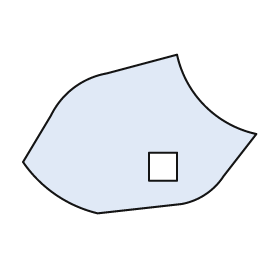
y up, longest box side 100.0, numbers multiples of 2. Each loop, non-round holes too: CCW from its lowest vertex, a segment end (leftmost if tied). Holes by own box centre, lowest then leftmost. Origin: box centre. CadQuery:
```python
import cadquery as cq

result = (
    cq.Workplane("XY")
    .moveTo(-18.0, -34.0)
    .lineTo(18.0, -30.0)
    .threePointArc((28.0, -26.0), (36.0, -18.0))
    .lineTo(50.0, 0.0)
    .threePointArc((28.0, 12.0), (16.0, 34.0))
    .lineTo(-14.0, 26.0)
    .threePointArc((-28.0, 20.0), (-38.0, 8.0))
    .lineTo(-50.0, -12.0)
    .threePointArc((-36.0, -26.0), (-18.0, -34.0))
    .close()
    .moveTo(4.0, -20.0)
    .lineTo(16.0, -20.0)
    .lineTo(16.0, -8.0)
    .lineTo(4.0, -8.0)
    .close()
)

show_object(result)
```